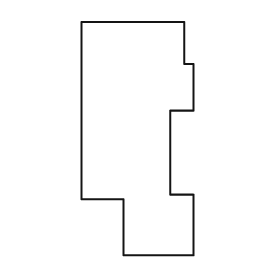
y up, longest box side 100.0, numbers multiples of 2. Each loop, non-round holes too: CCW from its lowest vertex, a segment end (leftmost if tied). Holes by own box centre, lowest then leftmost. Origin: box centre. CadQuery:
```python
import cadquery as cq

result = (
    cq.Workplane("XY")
    .moveTo(-6.0, -50.0)
    .lineTo(24.0, -50.0)
    .lineTo(24.0, -24.0)
    .lineTo(14.0, -24.0)
    .lineTo(14.0, 12.0)
    .lineTo(24.0, 12.0)
    .lineTo(24.0, 32.0)
    .lineTo(20.0, 32.0)
    .lineTo(20.0, 50.0)
    .lineTo(-24.0, 50.0)
    .lineTo(-24.0, -26.0)
    .lineTo(-6.0, -26.0)
    .close()
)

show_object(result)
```